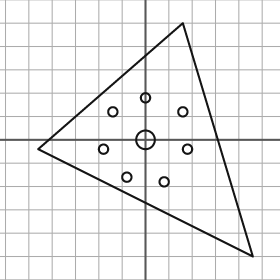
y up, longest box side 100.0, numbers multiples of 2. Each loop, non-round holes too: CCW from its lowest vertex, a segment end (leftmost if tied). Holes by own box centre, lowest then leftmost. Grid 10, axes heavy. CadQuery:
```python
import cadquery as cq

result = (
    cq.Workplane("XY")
    .moveTo(46.0, -50.0)
    .lineTo(16.0, 50.0)
    .lineTo(-46.0, -4.0)
    .close()
    .moveTo(8.0, -18.0)
    .circle(2.0)
    .moveTo(-8.0, -16.0)
    .circle(2.0)
    .moveTo(-18.0, -4.0)
    .circle(2.0)
    .moveTo(18.0, -4.0)
    .circle(2.0)
    .moveTo(0.0, 0.0)
    .circle(4.0)
    .moveTo(-14.0, 12.0)
    .circle(2.0)
    .moveTo(16.0, 12.0)
    .circle(2.0)
    .moveTo(0.0, 18.0)
    .circle(2.0)
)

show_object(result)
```